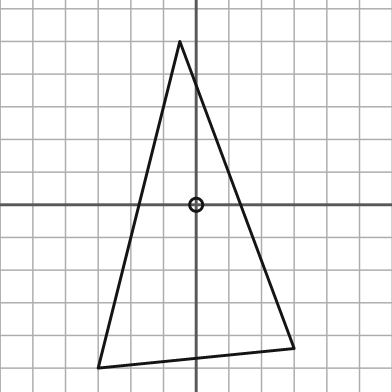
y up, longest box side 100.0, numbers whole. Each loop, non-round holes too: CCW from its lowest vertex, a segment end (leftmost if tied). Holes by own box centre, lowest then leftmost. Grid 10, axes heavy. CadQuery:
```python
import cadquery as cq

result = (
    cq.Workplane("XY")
    .moveTo(-30.0, -50.0)
    .lineTo(30.0, -44.0)
    .lineTo(-5.0, 50.0)
    .close()
    .moveTo(0.0, 0.0)
    .circle(2.0)
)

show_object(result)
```